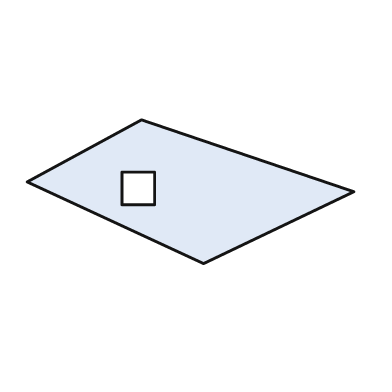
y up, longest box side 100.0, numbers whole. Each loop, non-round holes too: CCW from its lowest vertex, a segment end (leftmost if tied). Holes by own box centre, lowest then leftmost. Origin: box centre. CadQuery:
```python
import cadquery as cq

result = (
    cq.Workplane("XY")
    .moveTo(4.0, -22.0)
    .lineTo(50.0, 0.0)
    .lineTo(-15.0, 22.0)
    .lineTo(-50.0, 3.0)
    .close()
    .moveTo(-21.0, -4.0)
    .lineTo(-11.0, -4.0)
    .lineTo(-11.0, 6.0)
    .lineTo(-21.0, 6.0)
    .close()
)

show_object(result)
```